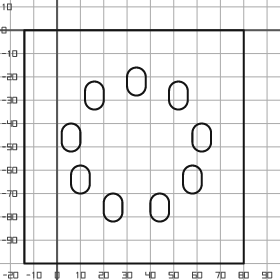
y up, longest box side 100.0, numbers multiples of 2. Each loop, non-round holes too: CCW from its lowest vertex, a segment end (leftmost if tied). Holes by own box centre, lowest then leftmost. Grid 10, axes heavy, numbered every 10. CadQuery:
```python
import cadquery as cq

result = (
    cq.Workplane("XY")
    .moveTo(-14.0, -100.0)
    .lineTo(80.0, -100.0)
    .lineTo(80.0, 0.0)
    .lineTo(-14.0, 0.0)
    .close()
    .moveTo(20.0, -78.0)
    .threePointArc((24.0, -82.0), (28.0, -78.0))
    .lineTo(28.0, -74.0)
    .threePointArc((24.0, -70.0), (20.0, -74.0))
    .close()
    .moveTo(40.0, -78.0)
    .threePointArc((44.0, -82.0), (48.0, -78.0))
    .lineTo(48.0, -74.0)
    .threePointArc((44.0, -70.0), (40.0, -74.0))
    .close()
    .moveTo(6.0, -66.0)
    .threePointArc((10.0, -70.0), (14.0, -66.0))
    .lineTo(14.0, -62.0)
    .threePointArc((10.0, -58.0), (6.0, -62.0))
    .close()
    .moveTo(54.0, -66.0)
    .threePointArc((58.0, -70.0), (62.0, -66.0))
    .lineTo(62.0, -62.0)
    .threePointArc((58.0, -58.0), (54.0, -62.0))
    .close()
    .moveTo(2.0, -48.0)
    .threePointArc((6.0, -52.0), (10.0, -48.0))
    .lineTo(10.0, -44.0)
    .threePointArc((6.0, -40.0), (2.0, -44.0))
    .close()
    .moveTo(58.0, -48.0)
    .threePointArc((62.0, -52.0), (66.0, -48.0))
    .lineTo(66.0, -44.0)
    .threePointArc((62.0, -40.0), (58.0, -44.0))
    .close()
    .moveTo(12.0, -30.0)
    .threePointArc((16.0, -34.0), (20.0, -30.0))
    .lineTo(20.0, -26.0)
    .threePointArc((16.0, -22.0), (12.0, -26.0))
    .close()
    .moveTo(48.0, -30.0)
    .threePointArc((52.0, -34.0), (56.0, -30.0))
    .lineTo(56.0, -26.0)
    .threePointArc((52.0, -22.0), (48.0, -26.0))
    .close()
    .moveTo(30.0, -24.0)
    .threePointArc((34.0, -28.0), (38.0, -24.0))
    .lineTo(38.0, -20.0)
    .threePointArc((34.0, -16.0), (30.0, -20.0))
    .close()
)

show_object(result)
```